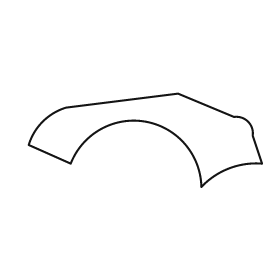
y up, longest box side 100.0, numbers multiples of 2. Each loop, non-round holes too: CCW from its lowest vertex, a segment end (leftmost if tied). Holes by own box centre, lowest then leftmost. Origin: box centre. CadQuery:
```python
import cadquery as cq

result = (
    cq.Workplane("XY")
    .moveTo(24.0, -20.0)
    .threePointArc((36.0, -12.0), (50.0, -10.0))
    .lineTo(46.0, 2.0)
    .threePointArc((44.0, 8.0), (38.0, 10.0))
    .lineTo(14.0, 20.0)
    .lineTo(-34.0, 14.0)
    .threePointArc((-44.0, 8.0), (-50.0, -2.0))
    .lineTo(-32.0, -10.0)
    .threePointArc((0.0, 8.0), (24.0, -20.0))
    .close()
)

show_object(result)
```